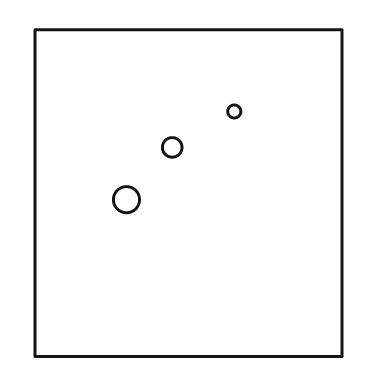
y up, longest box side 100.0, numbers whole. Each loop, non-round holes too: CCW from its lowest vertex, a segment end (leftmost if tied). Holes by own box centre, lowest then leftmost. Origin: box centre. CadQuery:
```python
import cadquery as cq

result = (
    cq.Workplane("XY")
    .moveTo(-47.0, -50.0)
    .lineTo(47.0, -50.0)
    .lineTo(47.0, 50.0)
    .lineTo(-47.0, 50.0)
    .close()
    .moveTo(-19.0, -2.0)
    .circle(4.0)
    .moveTo(-5.0, 14.0)
    .circle(3.0)
    .moveTo(14.0, 25.0)
    .circle(2.0)
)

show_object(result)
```